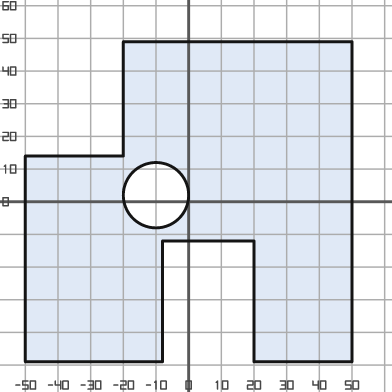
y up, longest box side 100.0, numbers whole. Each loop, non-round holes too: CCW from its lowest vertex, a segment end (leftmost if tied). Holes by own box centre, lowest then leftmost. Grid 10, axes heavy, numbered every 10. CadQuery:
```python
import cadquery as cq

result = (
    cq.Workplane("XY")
    .moveTo(-50.0, -49.0)
    .lineTo(-8.0, -49.0)
    .lineTo(-8.0, -12.0)
    .lineTo(20.0, -12.0)
    .lineTo(20.0, -49.0)
    .lineTo(50.0, -49.0)
    .lineTo(50.0, 49.0)
    .lineTo(-20.0, 49.0)
    .lineTo(-20.0, 14.0)
    .lineTo(-50.0, 14.0)
    .close()
    .moveTo(-10.0, 2.0)
    .circle(10.0)
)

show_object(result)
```